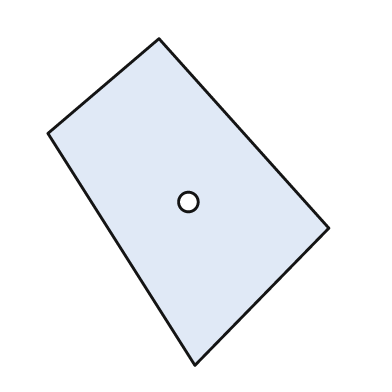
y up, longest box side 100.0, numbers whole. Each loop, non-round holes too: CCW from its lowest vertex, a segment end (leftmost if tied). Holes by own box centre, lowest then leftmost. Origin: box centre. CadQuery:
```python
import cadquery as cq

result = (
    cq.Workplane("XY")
    .moveTo(2.0, -50.0)
    .lineTo(43.0, -8.0)
    .lineTo(-9.0, 50.0)
    .lineTo(-43.0, 21.0)
    .close()
    .moveTo(0.0, 0.0)
    .circle(3.0)
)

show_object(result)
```